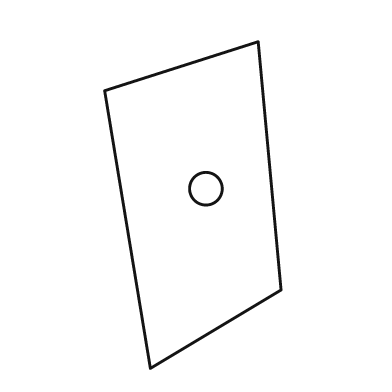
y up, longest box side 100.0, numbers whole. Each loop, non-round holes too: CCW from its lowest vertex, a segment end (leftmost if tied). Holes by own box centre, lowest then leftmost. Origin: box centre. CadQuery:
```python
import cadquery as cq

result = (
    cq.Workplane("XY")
    .moveTo(-13.0, -50.0)
    .lineTo(27.0, -26.0)
    .lineTo(20.0, 50.0)
    .lineTo(-27.0, 35.0)
    .close()
    .moveTo(4.0, 5.0)
    .circle(5.0)
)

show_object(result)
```